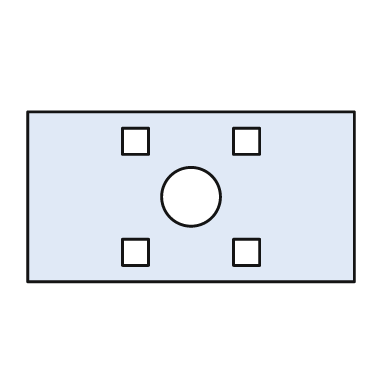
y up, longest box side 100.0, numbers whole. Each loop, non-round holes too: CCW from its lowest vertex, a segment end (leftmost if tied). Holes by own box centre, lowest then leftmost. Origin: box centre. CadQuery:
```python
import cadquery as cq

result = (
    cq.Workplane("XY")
    .moveTo(-50.0, -26.0)
    .lineTo(50.0, -26.0)
    .lineTo(50.0, 26.0)
    .lineTo(-50.0, 26.0)
    .close()
    .moveTo(-21.0, -21.0)
    .lineTo(-13.0, -21.0)
    .lineTo(-13.0, -13.0)
    .lineTo(-21.0, -13.0)
    .close()
    .moveTo(13.0, -21.0)
    .lineTo(21.0, -21.0)
    .lineTo(21.0, -13.0)
    .lineTo(13.0, -13.0)
    .close()
    .moveTo(0.0, 0.0)
    .circle(9.0)
    .moveTo(-21.0, 13.0)
    .lineTo(-13.0, 13.0)
    .lineTo(-13.0, 21.0)
    .lineTo(-21.0, 21.0)
    .close()
    .moveTo(13.0, 13.0)
    .lineTo(21.0, 13.0)
    .lineTo(21.0, 21.0)
    .lineTo(13.0, 21.0)
    .close()
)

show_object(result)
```